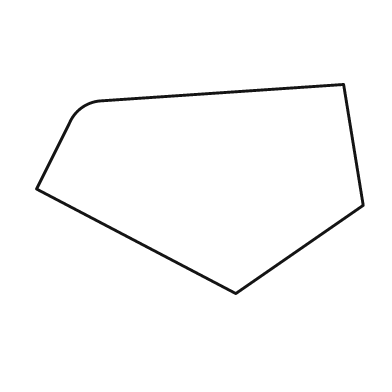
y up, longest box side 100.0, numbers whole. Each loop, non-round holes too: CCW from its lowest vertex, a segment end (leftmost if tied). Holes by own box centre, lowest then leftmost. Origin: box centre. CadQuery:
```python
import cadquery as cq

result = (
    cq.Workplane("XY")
    .moveTo(11.0, -32.0)
    .lineTo(50.0, -5.0)
    .lineTo(44.0, 32.0)
    .lineTo(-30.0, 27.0)
    .threePointArc((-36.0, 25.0), (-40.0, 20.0))
    .lineTo(-50.0, 0.0)
    .close()
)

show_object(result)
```